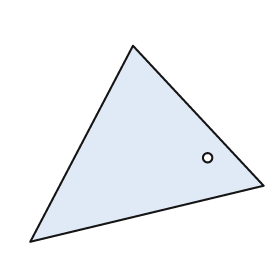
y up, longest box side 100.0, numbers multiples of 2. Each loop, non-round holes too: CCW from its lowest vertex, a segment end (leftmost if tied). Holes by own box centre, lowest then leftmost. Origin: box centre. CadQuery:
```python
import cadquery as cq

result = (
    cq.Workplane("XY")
    .moveTo(-50.0, -42.0)
    .lineTo(50.0, -18.0)
    .lineTo(-6.0, 42.0)
    .close()
    .moveTo(26.0, -6.0)
    .circle(2.0)
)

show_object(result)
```